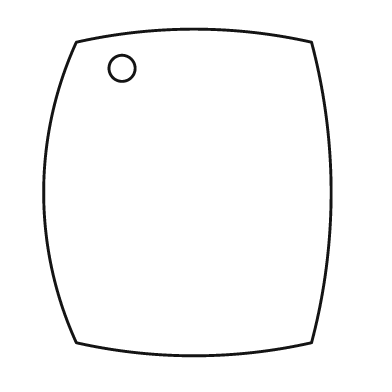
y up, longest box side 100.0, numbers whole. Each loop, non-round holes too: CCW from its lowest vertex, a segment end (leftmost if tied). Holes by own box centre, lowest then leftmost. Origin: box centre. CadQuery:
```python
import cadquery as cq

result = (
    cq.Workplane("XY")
    .moveTo(-34.0, -46.0)
    .threePointArc((2.0, -50.0), (38.0, -46.0))
    .threePointArc((44.0, 0.0), (38.0, 46.0))
    .threePointArc((2.0, 50.0), (-34.0, 46.0))
    .threePointArc((-44.0, 0.0), (-34.0, -46.0))
    .close()
    .moveTo(-20.0, 38.0)
    .circle(4.0)
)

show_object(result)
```